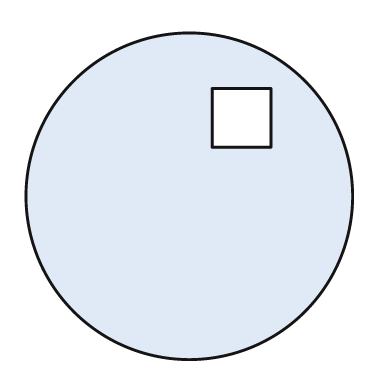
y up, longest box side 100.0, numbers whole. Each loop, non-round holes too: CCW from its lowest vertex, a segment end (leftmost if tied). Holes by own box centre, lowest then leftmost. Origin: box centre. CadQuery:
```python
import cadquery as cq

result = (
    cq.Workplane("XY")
    .moveTo(0.0, 0.0)
    .circle(50.0)
    .moveTo(7.0, 15.0)
    .lineTo(25.0, 15.0)
    .lineTo(25.0, 33.0)
    .lineTo(7.0, 33.0)
    .close()
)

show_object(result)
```